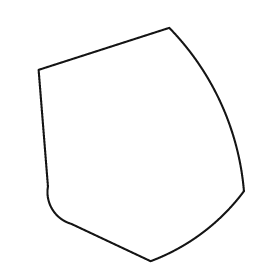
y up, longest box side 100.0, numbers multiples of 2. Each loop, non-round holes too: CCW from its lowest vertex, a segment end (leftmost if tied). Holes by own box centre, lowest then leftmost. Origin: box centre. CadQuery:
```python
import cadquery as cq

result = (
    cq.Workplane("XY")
    .moveTo(4.0, -50.0)
    .threePointArc((26.0, -38.0), (44.0, -20.0))
    .threePointArc((34.0, 18.0), (12.0, 50.0))
    .lineTo(-44.0, 32.0)
    .lineTo(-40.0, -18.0)
    .threePointArc((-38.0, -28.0), (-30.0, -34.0))
    .close()
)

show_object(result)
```